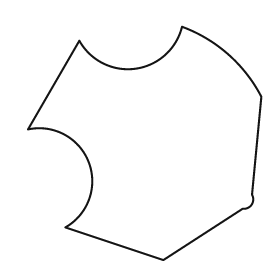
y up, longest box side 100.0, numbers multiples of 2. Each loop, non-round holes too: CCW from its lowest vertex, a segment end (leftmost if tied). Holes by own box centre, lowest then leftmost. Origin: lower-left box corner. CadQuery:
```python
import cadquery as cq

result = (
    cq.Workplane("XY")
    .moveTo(58.0, 0.0)
    .lineTo(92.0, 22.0)
    .threePointArc((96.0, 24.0), (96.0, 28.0))
    .lineTo(100.0, 70.0)
    .threePointArc((86.0, 88.0), (66.0, 100.0))
    .threePointArc((46.0, 82.0), (22.0, 94.0))
    .lineTo(0.0, 56.0)
    .threePointArc((26.0, 42.0), (16.0, 14.0))
    .close()
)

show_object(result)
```